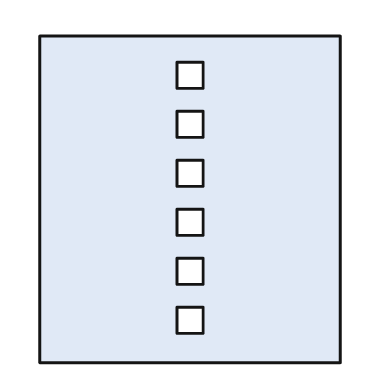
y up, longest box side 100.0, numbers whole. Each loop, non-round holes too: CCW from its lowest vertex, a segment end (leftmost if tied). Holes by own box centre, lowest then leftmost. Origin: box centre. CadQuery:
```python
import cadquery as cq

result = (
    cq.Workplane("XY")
    .moveTo(-46.0, -50.0)
    .lineTo(46.0, -50.0)
    .lineTo(46.0, 50.0)
    .lineTo(-46.0, 50.0)
    .close()
    .moveTo(-4.0, -41.0)
    .lineTo(4.0, -41.0)
    .lineTo(4.0, -33.0)
    .lineTo(-4.0, -33.0)
    .close()
    .moveTo(-4.0, -26.0)
    .lineTo(4.0, -26.0)
    .lineTo(4.0, -18.0)
    .lineTo(-4.0, -18.0)
    .close()
    .moveTo(-4.0, -11.0)
    .lineTo(4.0, -11.0)
    .lineTo(4.0, -3.0)
    .lineTo(-4.0, -3.0)
    .close()
    .moveTo(-4.0, 4.0)
    .lineTo(4.0, 4.0)
    .lineTo(4.0, 12.0)
    .lineTo(-4.0, 12.0)
    .close()
    .moveTo(-4.0, 19.0)
    .lineTo(4.0, 19.0)
    .lineTo(4.0, 27.0)
    .lineTo(-4.0, 27.0)
    .close()
    .moveTo(-4.0, 34.0)
    .lineTo(4.0, 34.0)
    .lineTo(4.0, 42.0)
    .lineTo(-4.0, 42.0)
    .close()
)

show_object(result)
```